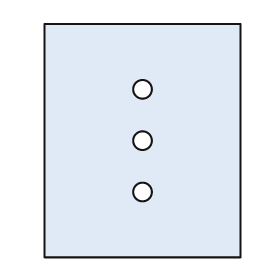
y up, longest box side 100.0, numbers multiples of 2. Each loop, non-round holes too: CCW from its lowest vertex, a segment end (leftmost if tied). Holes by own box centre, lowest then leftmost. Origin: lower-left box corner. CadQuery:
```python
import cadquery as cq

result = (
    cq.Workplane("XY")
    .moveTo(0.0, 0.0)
    .lineTo(84.0, 0.0)
    .lineTo(84.0, 100.0)
    .lineTo(0.0, 100.0)
    .close()
    .moveTo(42.0, 28.0)
    .circle(4.0)
    .moveTo(42.0, 50.0)
    .circle(4.0)
    .moveTo(42.0, 72.0)
    .circle(4.0)
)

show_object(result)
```